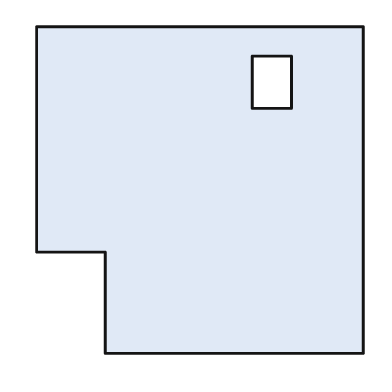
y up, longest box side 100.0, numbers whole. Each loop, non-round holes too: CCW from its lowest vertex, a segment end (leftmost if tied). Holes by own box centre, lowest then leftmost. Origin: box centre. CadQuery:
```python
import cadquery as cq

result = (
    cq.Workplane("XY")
    .moveTo(-29.0, -50.0)
    .lineTo(50.0, -50.0)
    .lineTo(50.0, 50.0)
    .lineTo(-50.0, 50.0)
    .lineTo(-50.0, -19.0)
    .lineTo(-29.0, -19.0)
    .close()
    .moveTo(16.0, 25.0)
    .lineTo(28.0, 25.0)
    .lineTo(28.0, 41.0)
    .lineTo(16.0, 41.0)
    .close()
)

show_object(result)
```